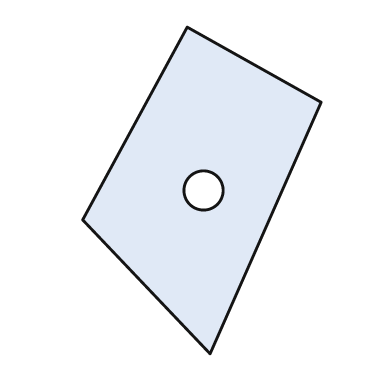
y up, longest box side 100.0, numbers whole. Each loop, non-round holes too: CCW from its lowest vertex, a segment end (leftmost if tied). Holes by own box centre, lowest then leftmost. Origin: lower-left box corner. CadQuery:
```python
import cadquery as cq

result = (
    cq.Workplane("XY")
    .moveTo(39.0, 0.0)
    .lineTo(73.0, 77.0)
    .lineTo(32.0, 100.0)
    .lineTo(0.0, 41.0)
    .close()
    .moveTo(37.0, 50.0)
    .circle(6.0)
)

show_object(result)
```